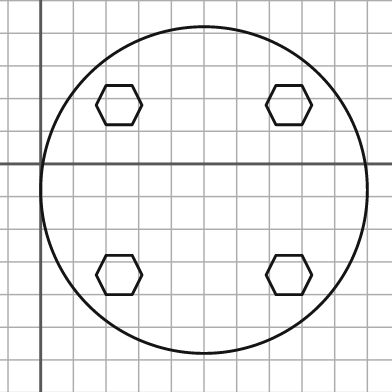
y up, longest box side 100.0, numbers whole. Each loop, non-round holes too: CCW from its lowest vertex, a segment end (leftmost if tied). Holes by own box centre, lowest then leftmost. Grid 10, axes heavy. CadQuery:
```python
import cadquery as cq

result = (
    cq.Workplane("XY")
    .moveTo(50.0, -8.0)
    .circle(50.0)
    .moveTo(20.0, -40.0)
    .lineTo(28.0, -40.0)
    .lineTo(31.0, -34.0)
    .lineTo(28.0, -28.0)
    .lineTo(20.0, -28.0)
    .lineTo(17.0, -34.0)
    .close()
    .moveTo(72.0, -40.0)
    .lineTo(80.0, -40.0)
    .lineTo(83.0, -34.0)
    .lineTo(80.0, -28.0)
    .lineTo(72.0, -28.0)
    .lineTo(69.0, -34.0)
    .close()
    .moveTo(20.0, 12.0)
    .lineTo(28.0, 12.0)
    .lineTo(31.0, 18.0)
    .lineTo(28.0, 24.0)
    .lineTo(20.0, 24.0)
    .lineTo(17.0, 18.0)
    .close()
    .moveTo(72.0, 12.0)
    .lineTo(80.0, 12.0)
    .lineTo(83.0, 18.0)
    .lineTo(80.0, 24.0)
    .lineTo(72.0, 24.0)
    .lineTo(69.0, 18.0)
    .close()
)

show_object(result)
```